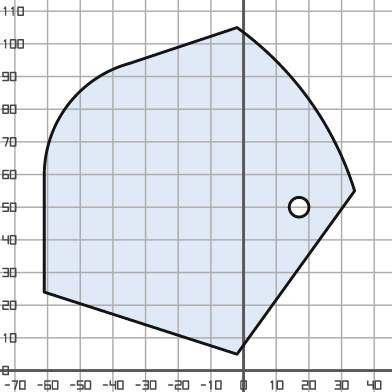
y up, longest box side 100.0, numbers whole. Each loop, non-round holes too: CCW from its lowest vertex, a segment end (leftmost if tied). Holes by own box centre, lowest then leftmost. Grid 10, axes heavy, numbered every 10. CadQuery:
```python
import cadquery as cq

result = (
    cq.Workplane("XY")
    .moveTo(-2.0, 5.0)
    .lineTo(34.0, 55.0)
    .threePointArc((20.0, 83.0), (-2.0, 105.0))
    .lineTo(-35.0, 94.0)
    .threePointArc((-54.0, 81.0), (-61.0, 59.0))
    .lineTo(-61.0, 24.0)
    .close()
    .moveTo(17.0, 50.0)
    .circle(3.0)
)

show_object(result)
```